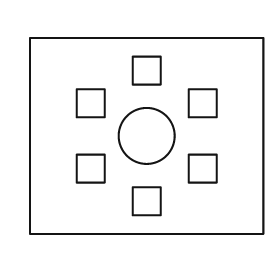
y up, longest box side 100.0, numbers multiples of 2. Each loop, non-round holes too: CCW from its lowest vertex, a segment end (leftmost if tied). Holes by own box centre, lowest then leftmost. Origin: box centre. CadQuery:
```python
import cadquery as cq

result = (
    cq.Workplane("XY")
    .moveTo(-50.0, -42.0)
    .lineTo(50.0, -42.0)
    .lineTo(50.0, 42.0)
    .lineTo(-50.0, 42.0)
    .close()
    .moveTo(-6.0, -34.0)
    .lineTo(6.0, -34.0)
    .lineTo(6.0, -22.0)
    .lineTo(-6.0, -22.0)
    .close()
    .moveTo(-30.0, -20.0)
    .lineTo(-18.0, -20.0)
    .lineTo(-18.0, -8.0)
    .lineTo(-30.0, -8.0)
    .close()
    .moveTo(18.0, -20.0)
    .lineTo(30.0, -20.0)
    .lineTo(30.0, -8.0)
    .lineTo(18.0, -8.0)
    .close()
    .moveTo(0.0, 0.0)
    .circle(12.0)
    .moveTo(-30.0, 8.0)
    .lineTo(-18.0, 8.0)
    .lineTo(-18.0, 20.0)
    .lineTo(-30.0, 20.0)
    .close()
    .moveTo(18.0, 8.0)
    .lineTo(30.0, 8.0)
    .lineTo(30.0, 20.0)
    .lineTo(18.0, 20.0)
    .close()
    .moveTo(-6.0, 22.0)
    .lineTo(6.0, 22.0)
    .lineTo(6.0, 34.0)
    .lineTo(-6.0, 34.0)
    .close()
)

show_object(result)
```